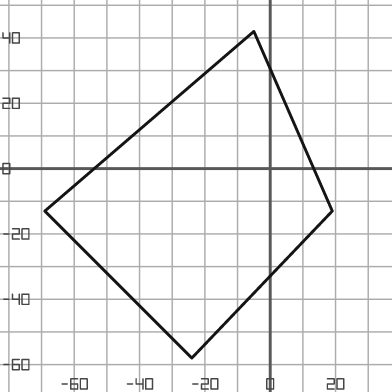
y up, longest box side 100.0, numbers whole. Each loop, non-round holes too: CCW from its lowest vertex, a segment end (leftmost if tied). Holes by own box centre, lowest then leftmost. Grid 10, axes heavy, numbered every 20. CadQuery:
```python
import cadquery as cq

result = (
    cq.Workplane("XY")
    .moveTo(-24.0, -58.0)
    .lineTo(19.0, -13.0)
    .lineTo(-5.0, 42.0)
    .lineTo(-69.0, -13.0)
    .close()
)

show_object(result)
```